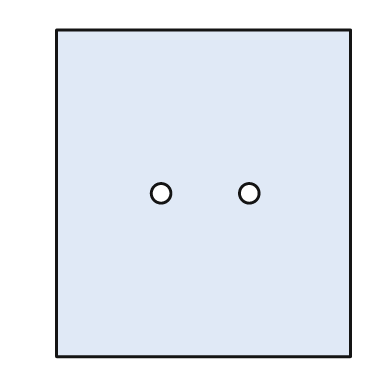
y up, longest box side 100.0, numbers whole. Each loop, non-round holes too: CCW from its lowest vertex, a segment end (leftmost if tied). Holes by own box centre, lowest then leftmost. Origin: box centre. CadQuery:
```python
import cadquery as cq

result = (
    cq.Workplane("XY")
    .moveTo(-45.0, -50.0)
    .lineTo(45.0, -50.0)
    .lineTo(45.0, 50.0)
    .lineTo(-45.0, 50.0)
    .close()
    .moveTo(-13.0, 0.0)
    .circle(3.0)
    .moveTo(14.0, 0.0)
    .circle(3.0)
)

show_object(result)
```